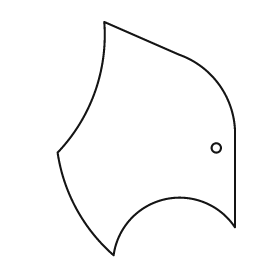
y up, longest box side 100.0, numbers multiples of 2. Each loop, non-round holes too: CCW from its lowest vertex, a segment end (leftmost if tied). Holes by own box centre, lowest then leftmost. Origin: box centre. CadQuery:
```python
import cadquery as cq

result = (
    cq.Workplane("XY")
    .moveTo(-14.0, -50.0)
    .threePointArc((8.0, -26.0), (38.0, -38.0))
    .lineTo(38.0, 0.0)
    .threePointArc((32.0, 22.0), (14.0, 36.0))
    .lineTo(-18.0, 50.0)
    .threePointArc((-22.0, 20.0), (-38.0, -6.0))
    .threePointArc((-30.0, -30.0), (-14.0, -50.0))
    .close()
    .moveTo(30.0, -4.0)
    .circle(2.0)
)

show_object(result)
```